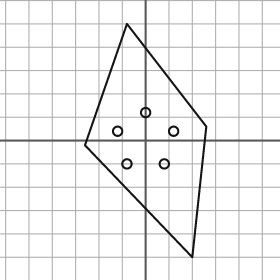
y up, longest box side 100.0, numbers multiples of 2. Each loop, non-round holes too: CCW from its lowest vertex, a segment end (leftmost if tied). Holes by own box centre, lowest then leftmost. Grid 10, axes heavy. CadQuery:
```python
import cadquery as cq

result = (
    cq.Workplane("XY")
    .moveTo(20.0, -50.0)
    .lineTo(26.0, 6.0)
    .lineTo(-8.0, 50.0)
    .lineTo(-26.0, -2.0)
    .close()
    .moveTo(-8.0, -10.0)
    .circle(2.0)
    .moveTo(8.0, -10.0)
    .circle(2.0)
    .moveTo(-12.0, 4.0)
    .circle(2.0)
    .moveTo(12.0, 4.0)
    .circle(2.0)
    .moveTo(0.0, 12.0)
    .circle(2.0)
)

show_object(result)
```